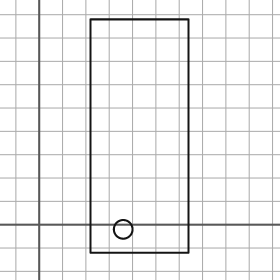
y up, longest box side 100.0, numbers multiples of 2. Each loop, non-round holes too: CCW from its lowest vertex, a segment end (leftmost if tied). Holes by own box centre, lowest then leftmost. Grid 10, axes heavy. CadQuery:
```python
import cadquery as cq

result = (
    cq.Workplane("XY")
    .moveTo(22.0, -12.0)
    .lineTo(64.0, -12.0)
    .lineTo(64.0, 88.0)
    .lineTo(22.0, 88.0)
    .close()
    .moveTo(36.0, -2.0)
    .circle(4.0)
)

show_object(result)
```